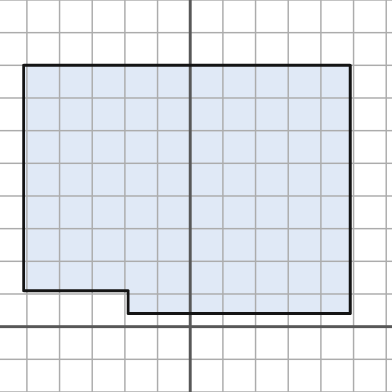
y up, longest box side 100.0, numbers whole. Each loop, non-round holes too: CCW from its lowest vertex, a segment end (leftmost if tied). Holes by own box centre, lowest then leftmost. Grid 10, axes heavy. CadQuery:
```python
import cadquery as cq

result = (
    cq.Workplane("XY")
    .moveTo(-19.0, 4.0)
    .lineTo(49.0, 4.0)
    .lineTo(49.0, 80.0)
    .lineTo(-51.0, 80.0)
    .lineTo(-51.0, 11.0)
    .lineTo(-19.0, 11.0)
    .close()
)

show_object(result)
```